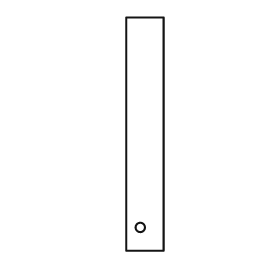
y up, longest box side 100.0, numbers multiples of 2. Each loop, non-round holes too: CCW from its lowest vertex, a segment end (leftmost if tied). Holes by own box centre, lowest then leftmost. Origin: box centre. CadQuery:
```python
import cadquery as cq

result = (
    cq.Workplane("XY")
    .moveTo(-8.0, -50.0)
    .lineTo(8.0, -50.0)
    .lineTo(8.0, 50.0)
    .lineTo(-8.0, 50.0)
    .close()
    .moveTo(-2.0, -40.0)
    .circle(2.0)
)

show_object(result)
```